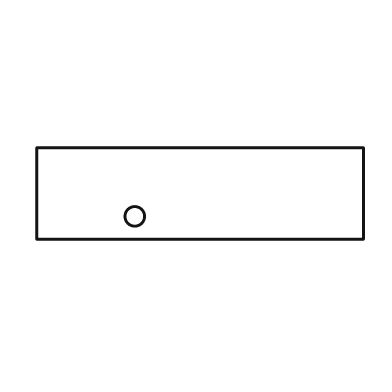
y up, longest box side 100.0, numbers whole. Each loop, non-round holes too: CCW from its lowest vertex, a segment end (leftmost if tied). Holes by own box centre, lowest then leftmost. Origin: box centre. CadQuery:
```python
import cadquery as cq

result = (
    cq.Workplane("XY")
    .moveTo(-50.0, -14.0)
    .lineTo(50.0, -14.0)
    .lineTo(50.0, 14.0)
    .lineTo(-50.0, 14.0)
    .close()
    .moveTo(-20.0, -7.0)
    .circle(3.0)
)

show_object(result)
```